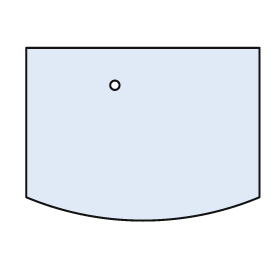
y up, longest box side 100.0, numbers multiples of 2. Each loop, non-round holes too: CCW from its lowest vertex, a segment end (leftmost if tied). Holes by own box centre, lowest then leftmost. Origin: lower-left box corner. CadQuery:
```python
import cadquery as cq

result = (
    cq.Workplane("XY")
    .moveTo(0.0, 10.0)
    .threePointArc((50.0, 0.0), (100.0, 10.0))
    .lineTo(100.0, 74.0)
    .lineTo(0.0, 74.0)
    .close()
    .moveTo(38.0, 58.0)
    .circle(2.0)
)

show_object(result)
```